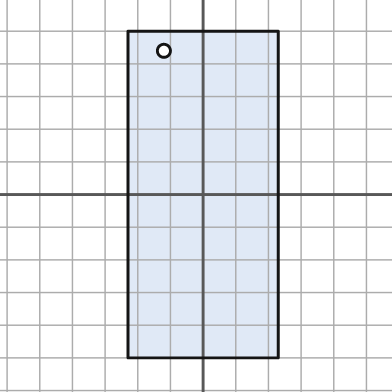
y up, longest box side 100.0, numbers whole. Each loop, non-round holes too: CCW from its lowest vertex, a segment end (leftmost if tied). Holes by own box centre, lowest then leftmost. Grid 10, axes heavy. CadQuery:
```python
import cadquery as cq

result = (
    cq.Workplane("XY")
    .moveTo(-23.0, -50.0)
    .lineTo(23.0, -50.0)
    .lineTo(23.0, 50.0)
    .lineTo(-23.0, 50.0)
    .close()
    .moveTo(-12.0, 44.0)
    .circle(2.0)
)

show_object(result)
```